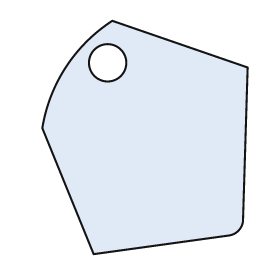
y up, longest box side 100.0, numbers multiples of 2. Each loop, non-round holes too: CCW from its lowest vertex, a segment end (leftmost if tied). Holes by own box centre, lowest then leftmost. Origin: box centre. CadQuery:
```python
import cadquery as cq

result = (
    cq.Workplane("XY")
    .moveTo(-22.0, -50.0)
    .lineTo(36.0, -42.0)
    .threePointArc((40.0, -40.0), (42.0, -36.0))
    .lineTo(44.0, 30.0)
    .lineTo(-14.0, 50.0)
    .threePointArc((-34.0, 30.0), (-44.0, 4.0))
    .close()
    .moveTo(-16.0, 32.0)
    .circle(8.0)
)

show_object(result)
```